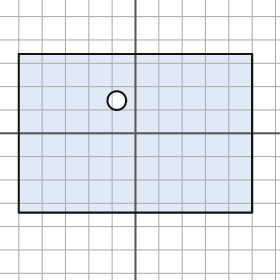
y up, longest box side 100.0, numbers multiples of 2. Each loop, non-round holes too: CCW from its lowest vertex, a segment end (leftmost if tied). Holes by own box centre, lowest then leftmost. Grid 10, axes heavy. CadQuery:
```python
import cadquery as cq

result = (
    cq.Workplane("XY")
    .moveTo(-50.0, -34.0)
    .lineTo(50.0, -34.0)
    .lineTo(50.0, 34.0)
    .lineTo(-50.0, 34.0)
    .close()
    .moveTo(-8.0, 14.0)
    .circle(4.0)
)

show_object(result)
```